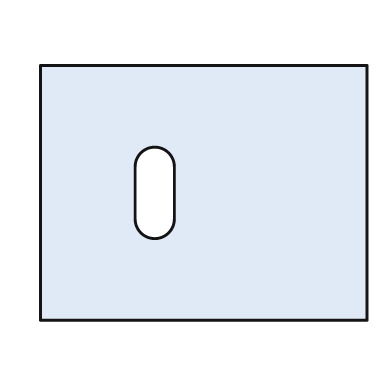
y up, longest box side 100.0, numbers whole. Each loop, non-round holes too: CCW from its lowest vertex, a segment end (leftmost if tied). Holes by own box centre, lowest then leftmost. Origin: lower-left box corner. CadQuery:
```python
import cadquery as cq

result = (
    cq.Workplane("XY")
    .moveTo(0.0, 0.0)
    .lineTo(100.0, 0.0)
    .lineTo(100.0, 78.0)
    .lineTo(0.0, 78.0)
    .close()
    .moveTo(29.0, 31.0)
    .threePointArc((35.0, 25.0), (41.0, 31.0))
    .lineTo(41.0, 47.0)
    .threePointArc((35.0, 53.0), (29.0, 47.0))
    .close()
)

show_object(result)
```